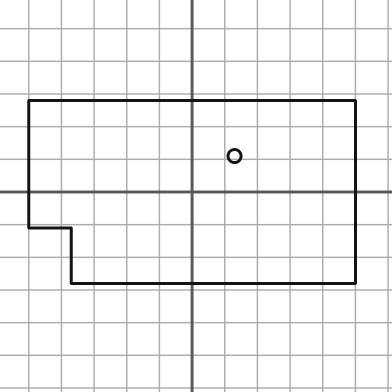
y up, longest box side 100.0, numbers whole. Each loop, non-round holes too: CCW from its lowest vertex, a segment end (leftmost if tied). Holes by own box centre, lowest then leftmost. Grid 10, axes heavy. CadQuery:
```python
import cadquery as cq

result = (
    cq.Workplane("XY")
    .moveTo(-37.0, -28.0)
    .lineTo(50.0, -28.0)
    .lineTo(50.0, 28.0)
    .lineTo(-50.0, 28.0)
    .lineTo(-50.0, -11.0)
    .lineTo(-37.0, -11.0)
    .close()
    .moveTo(13.0, 11.0)
    .circle(2.0)
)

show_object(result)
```